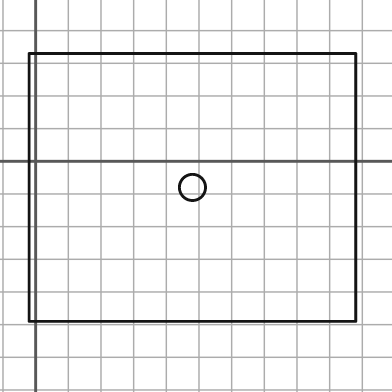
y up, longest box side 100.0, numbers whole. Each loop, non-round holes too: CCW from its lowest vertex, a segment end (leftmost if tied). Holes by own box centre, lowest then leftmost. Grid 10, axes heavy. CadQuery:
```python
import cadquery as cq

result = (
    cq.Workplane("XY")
    .moveTo(-2.0, -49.0)
    .lineTo(98.0, -49.0)
    .lineTo(98.0, 33.0)
    .lineTo(-2.0, 33.0)
    .close()
    .moveTo(48.0, -8.0)
    .circle(4.0)
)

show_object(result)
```